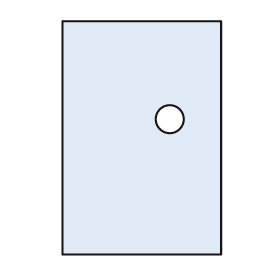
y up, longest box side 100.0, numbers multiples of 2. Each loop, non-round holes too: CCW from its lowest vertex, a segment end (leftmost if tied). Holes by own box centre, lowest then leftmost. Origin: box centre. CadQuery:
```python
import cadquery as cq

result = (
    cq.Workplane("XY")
    .moveTo(-34.0, -50.0)
    .lineTo(34.0, -50.0)
    .lineTo(34.0, 50.0)
    .lineTo(-34.0, 50.0)
    .close()
    .moveTo(12.0, 8.0)
    .circle(6.0)
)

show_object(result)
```